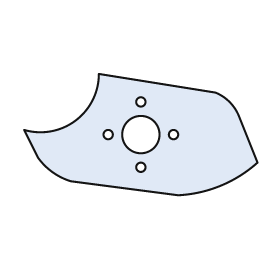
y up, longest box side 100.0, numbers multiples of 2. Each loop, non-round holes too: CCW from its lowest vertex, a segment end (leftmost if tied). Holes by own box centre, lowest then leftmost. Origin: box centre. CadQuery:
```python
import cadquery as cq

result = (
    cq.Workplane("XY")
    .moveTo(16.0, -26.0)
    .threePointArc((34.0, -22.0), (50.0, -12.0))
    .lineTo(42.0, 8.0)
    .threePointArc((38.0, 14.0), (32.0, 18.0))
    .lineTo(-18.0, 26.0)
    .threePointArc((-28.0, 6.0), (-50.0, 2.0))
    .lineTo(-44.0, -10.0)
    .threePointArc((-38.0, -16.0), (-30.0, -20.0))
    .close()
    .moveTo(0.0, -14.0)
    .circle(2.0)
    .moveTo(-14.0, 0.0)
    .circle(2.0)
    .moveTo(0.0, 0.0)
    .circle(8.0)
    .moveTo(14.0, 0.0)
    .circle(2.0)
    .moveTo(0.0, 14.0)
    .circle(2.0)
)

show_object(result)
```